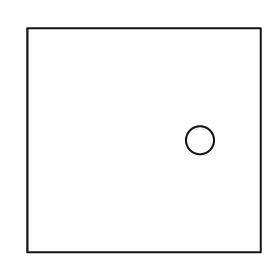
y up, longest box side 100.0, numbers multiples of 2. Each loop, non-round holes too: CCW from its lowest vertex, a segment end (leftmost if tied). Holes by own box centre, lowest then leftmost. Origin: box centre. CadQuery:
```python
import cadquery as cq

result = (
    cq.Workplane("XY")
    .moveTo(-50.0, -48.0)
    .lineTo(50.0, -48.0)
    .lineTo(50.0, 48.0)
    .lineTo(-50.0, 48.0)
    .close()
    .moveTo(24.0, 0.0)
    .circle(6.0)
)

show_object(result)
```